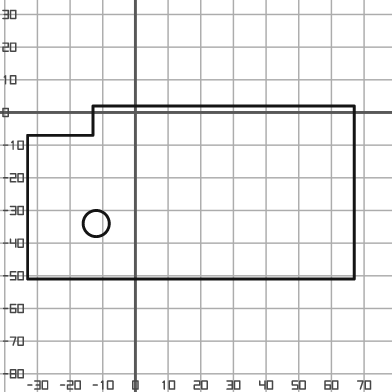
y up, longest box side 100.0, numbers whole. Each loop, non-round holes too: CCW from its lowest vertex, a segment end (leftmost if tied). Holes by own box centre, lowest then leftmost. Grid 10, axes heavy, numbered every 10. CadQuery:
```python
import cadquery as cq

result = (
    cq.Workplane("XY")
    .moveTo(-33.0, -51.0)
    .lineTo(67.0, -51.0)
    .lineTo(67.0, 2.0)
    .lineTo(-13.0, 2.0)
    .lineTo(-13.0, -7.0)
    .lineTo(-33.0, -7.0)
    .close()
    .moveTo(-12.0, -34.0)
    .circle(4.0)
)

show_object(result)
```